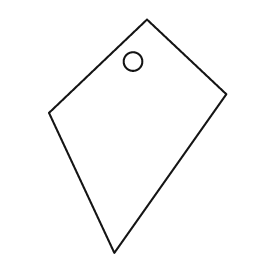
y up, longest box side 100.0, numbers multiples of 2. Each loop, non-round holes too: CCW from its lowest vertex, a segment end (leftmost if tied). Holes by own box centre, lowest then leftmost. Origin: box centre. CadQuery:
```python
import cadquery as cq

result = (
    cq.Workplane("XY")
    .moveTo(-10.0, -50.0)
    .lineTo(38.0, 18.0)
    .lineTo(4.0, 50.0)
    .lineTo(-38.0, 10.0)
    .close()
    .moveTo(-2.0, 32.0)
    .circle(4.0)
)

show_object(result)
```